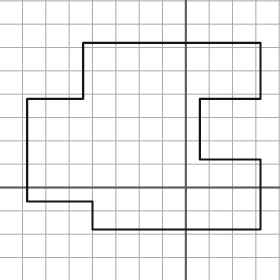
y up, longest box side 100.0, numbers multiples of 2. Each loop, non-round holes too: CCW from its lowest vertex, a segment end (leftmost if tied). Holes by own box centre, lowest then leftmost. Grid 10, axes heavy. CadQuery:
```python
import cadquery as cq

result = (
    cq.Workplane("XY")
    .moveTo(-40.0, -18.0)
    .lineTo(32.0, -18.0)
    .lineTo(32.0, 12.0)
    .lineTo(6.0, 12.0)
    .lineTo(6.0, 38.0)
    .lineTo(32.0, 38.0)
    .lineTo(32.0, 62.0)
    .lineTo(-44.0, 62.0)
    .lineTo(-44.0, 38.0)
    .lineTo(-68.0, 38.0)
    .lineTo(-68.0, -6.0)
    .lineTo(-40.0, -6.0)
    .close()
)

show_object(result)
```